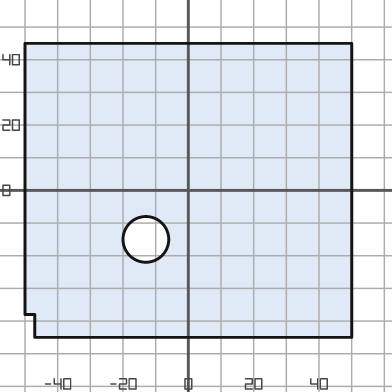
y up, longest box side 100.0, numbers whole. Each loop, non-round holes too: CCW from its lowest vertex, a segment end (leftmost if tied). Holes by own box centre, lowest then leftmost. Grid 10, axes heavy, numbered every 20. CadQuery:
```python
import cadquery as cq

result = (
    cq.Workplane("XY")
    .moveTo(-47.0, -45.0)
    .lineTo(50.0, -45.0)
    .lineTo(50.0, 45.0)
    .lineTo(-50.0, 45.0)
    .lineTo(-50.0, -38.0)
    .lineTo(-47.0, -38.0)
    .close()
    .moveTo(-13.0, -15.0)
    .circle(7.0)
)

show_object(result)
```